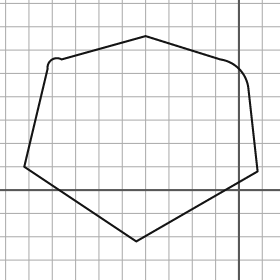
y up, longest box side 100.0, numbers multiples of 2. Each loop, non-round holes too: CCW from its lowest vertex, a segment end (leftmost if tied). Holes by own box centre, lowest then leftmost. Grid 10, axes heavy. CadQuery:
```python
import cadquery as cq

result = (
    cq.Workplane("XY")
    .moveTo(-44.0, -22.0)
    .lineTo(8.0, 8.0)
    .lineTo(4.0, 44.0)
    .threePointArc((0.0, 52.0), (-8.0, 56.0))
    .lineTo(-40.0, 66.0)
    .lineTo(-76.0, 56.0)
    .threePointArc((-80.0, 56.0), (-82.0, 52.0))
    .lineTo(-92.0, 10.0)
    .close()
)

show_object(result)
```